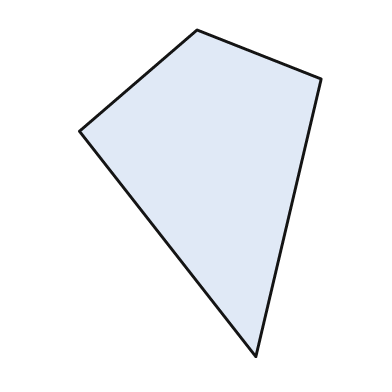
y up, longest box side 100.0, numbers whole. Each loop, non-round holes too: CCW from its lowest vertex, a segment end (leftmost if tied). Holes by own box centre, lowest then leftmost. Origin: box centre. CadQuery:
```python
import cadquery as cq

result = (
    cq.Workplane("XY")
    .moveTo(17.0, -50.0)
    .lineTo(37.0, 35.0)
    .lineTo(-1.0, 50.0)
    .lineTo(-37.0, 19.0)
    .close()
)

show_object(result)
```